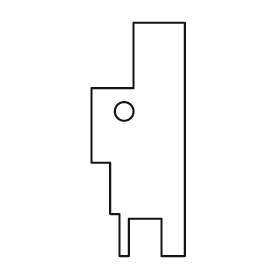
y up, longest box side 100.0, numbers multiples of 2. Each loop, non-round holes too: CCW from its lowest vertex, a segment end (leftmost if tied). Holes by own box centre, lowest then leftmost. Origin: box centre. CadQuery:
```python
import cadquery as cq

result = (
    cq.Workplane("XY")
    .moveTo(-8.0, -50.0)
    .lineTo(-4.0, -50.0)
    .lineTo(-4.0, -34.0)
    .lineTo(10.0, -34.0)
    .lineTo(10.0, -50.0)
    .lineTo(20.0, -50.0)
    .lineTo(20.0, 50.0)
    .lineTo(-2.0, 50.0)
    .lineTo(-2.0, 22.0)
    .lineTo(-20.0, 22.0)
    .lineTo(-20.0, -10.0)
    .lineTo(-12.0, -10.0)
    .lineTo(-12.0, -32.0)
    .lineTo(-8.0, -32.0)
    .close()
    .moveTo(-6.0, 12.0)
    .circle(4.0)
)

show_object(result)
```